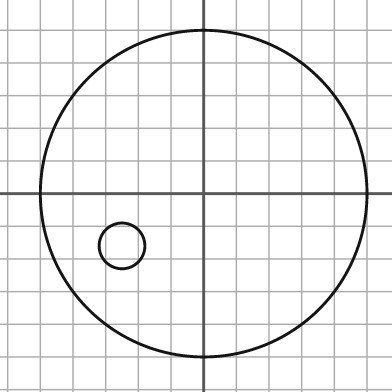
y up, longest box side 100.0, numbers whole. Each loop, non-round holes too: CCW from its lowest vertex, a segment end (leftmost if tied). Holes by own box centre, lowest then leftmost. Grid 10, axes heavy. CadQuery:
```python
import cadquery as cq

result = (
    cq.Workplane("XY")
    .moveTo(0.0, 0.0)
    .circle(50.0)
    .moveTo(-25.0, -16.0)
    .circle(7.0)
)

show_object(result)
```